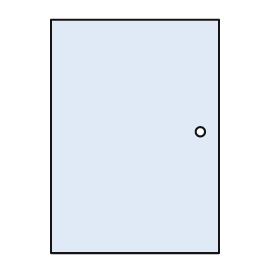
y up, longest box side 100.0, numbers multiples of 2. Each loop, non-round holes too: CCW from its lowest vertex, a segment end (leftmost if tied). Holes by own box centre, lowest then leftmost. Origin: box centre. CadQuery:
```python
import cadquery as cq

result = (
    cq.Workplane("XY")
    .moveTo(-36.0, -50.0)
    .lineTo(36.0, -50.0)
    .lineTo(36.0, 50.0)
    .lineTo(-36.0, 50.0)
    .close()
    .moveTo(28.0, 2.0)
    .circle(2.0)
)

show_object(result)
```